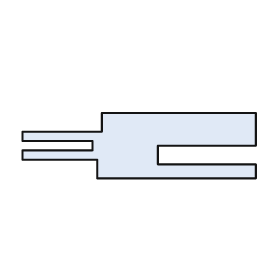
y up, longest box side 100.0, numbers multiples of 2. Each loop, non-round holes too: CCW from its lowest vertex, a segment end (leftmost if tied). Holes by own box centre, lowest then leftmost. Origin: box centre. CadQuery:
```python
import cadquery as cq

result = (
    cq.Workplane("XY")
    .moveTo(-18.0, -14.0)
    .lineTo(50.0, -14.0)
    .lineTo(50.0, -8.0)
    .lineTo(8.0, -8.0)
    .lineTo(8.0, 0.0)
    .lineTo(50.0, 0.0)
    .lineTo(50.0, 14.0)
    .lineTo(-16.0, 14.0)
    .lineTo(-16.0, 6.0)
    .lineTo(-50.0, 6.0)
    .lineTo(-50.0, 2.0)
    .lineTo(-20.0, 2.0)
    .lineTo(-20.0, -2.0)
    .lineTo(-50.0, -2.0)
    .lineTo(-50.0, -6.0)
    .lineTo(-18.0, -6.0)
    .close()
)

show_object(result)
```